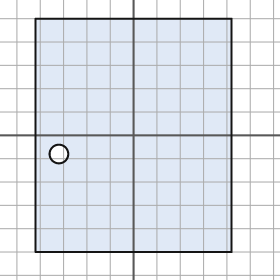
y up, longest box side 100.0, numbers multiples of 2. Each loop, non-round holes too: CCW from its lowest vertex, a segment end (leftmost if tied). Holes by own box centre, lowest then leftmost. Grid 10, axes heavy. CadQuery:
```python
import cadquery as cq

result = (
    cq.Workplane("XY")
    .moveTo(-42.0, -50.0)
    .lineTo(42.0, -50.0)
    .lineTo(42.0, 50.0)
    .lineTo(-42.0, 50.0)
    .close()
    .moveTo(-32.0, -8.0)
    .circle(4.0)
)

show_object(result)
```